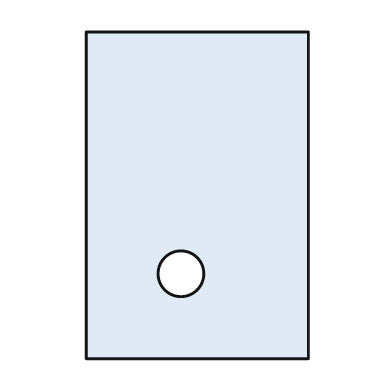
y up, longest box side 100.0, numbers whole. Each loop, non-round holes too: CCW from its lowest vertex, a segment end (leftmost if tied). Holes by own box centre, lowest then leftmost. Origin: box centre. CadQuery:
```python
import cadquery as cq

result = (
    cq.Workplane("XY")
    .moveTo(-34.0, -50.0)
    .lineTo(34.0, -50.0)
    .lineTo(34.0, 50.0)
    .lineTo(-34.0, 50.0)
    .close()
    .moveTo(-5.0, -24.0)
    .circle(7.0)
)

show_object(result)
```